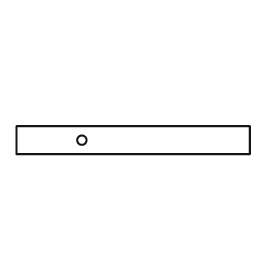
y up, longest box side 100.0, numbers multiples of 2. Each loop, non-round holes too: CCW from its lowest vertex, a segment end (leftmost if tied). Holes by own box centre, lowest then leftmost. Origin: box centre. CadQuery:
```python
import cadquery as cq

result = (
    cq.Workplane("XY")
    .moveTo(-50.0, -6.0)
    .lineTo(50.0, -6.0)
    .lineTo(50.0, 6.0)
    .lineTo(-50.0, 6.0)
    .close()
    .moveTo(-22.0, 0.0)
    .circle(2.0)
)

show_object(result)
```